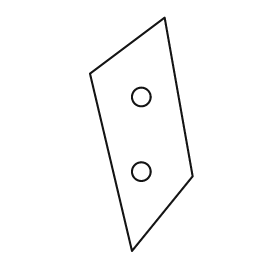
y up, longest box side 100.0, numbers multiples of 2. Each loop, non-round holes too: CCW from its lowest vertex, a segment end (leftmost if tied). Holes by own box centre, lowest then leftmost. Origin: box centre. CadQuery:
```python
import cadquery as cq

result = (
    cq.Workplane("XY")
    .moveTo(-4.0, -50.0)
    .lineTo(22.0, -18.0)
    .lineTo(10.0, 50.0)
    .lineTo(-22.0, 26.0)
    .close()
    .moveTo(0.0, -16.0)
    .circle(4.0)
    .moveTo(0.0, 16.0)
    .circle(4.0)
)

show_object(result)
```